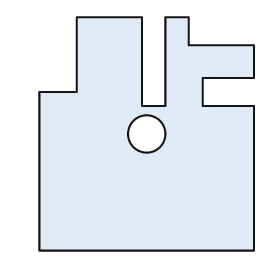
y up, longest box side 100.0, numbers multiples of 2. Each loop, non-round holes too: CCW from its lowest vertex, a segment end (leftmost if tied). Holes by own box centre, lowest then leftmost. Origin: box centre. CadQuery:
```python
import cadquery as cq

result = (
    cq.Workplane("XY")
    .moveTo(-46.0, -50.0)
    .lineTo(46.0, -50.0)
    .lineTo(46.0, 12.0)
    .lineTo(24.0, 12.0)
    .lineTo(24.0, 24.0)
    .lineTo(46.0, 24.0)
    .lineTo(46.0, 38.0)
    .lineTo(18.0, 38.0)
    .lineTo(18.0, 50.0)
    .lineTo(8.0, 50.0)
    .lineTo(8.0, 12.0)
    .lineTo(-2.0, 12.0)
    .lineTo(-2.0, 50.0)
    .lineTo(-30.0, 50.0)
    .lineTo(-30.0, 18.0)
    .lineTo(-46.0, 18.0)
    .close()
    .moveTo(0.0, 0.0)
    .circle(8.0)
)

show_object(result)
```